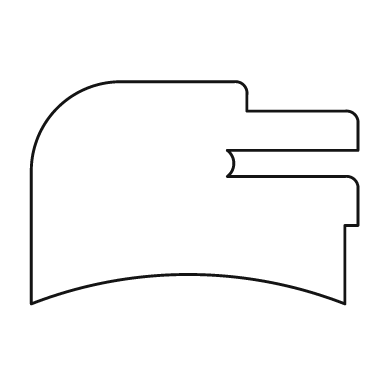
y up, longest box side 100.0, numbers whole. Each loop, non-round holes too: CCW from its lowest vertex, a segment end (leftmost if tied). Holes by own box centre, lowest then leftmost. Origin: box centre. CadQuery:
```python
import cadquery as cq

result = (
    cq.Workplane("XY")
    .moveTo(-50.0, -34.0)
    .threePointArc((-2.0, -25.0), (46.0, -34.0))
    .lineTo(46.0, -10.0)
    .lineTo(50.0, -10.0)
    .lineTo(50.0, 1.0)
    .threePointArc((49.0, 4.0), (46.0, 5.0))
    .lineTo(10.0, 5.0)
    .threePointArc((12.0, 9.0), (10.0, 13.0))
    .lineTo(50.0, 13.0)
    .lineTo(50.0, 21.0)
    .threePointArc((49.0, 24.0), (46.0, 25.0))
    .lineTo(16.0, 25.0)
    .lineTo(16.0, 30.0)
    .threePointArc((15.0, 33.0), (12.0, 34.0))
    .lineTo(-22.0, 34.0)
    .threePointArc((-42.0, 26.0), (-50.0, 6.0))
    .close()
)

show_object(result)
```